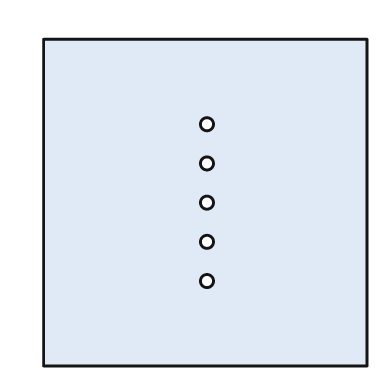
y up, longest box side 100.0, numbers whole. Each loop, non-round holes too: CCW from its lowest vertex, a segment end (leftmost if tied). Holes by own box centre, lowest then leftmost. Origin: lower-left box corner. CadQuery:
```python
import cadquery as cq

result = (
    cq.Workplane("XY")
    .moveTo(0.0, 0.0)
    .lineTo(99.0, 0.0)
    .lineTo(99.0, 100.0)
    .lineTo(0.0, 100.0)
    .close()
    .moveTo(50.0, 26.0)
    .circle(2.0)
    .moveTo(50.0, 38.0)
    .circle(2.0)
    .moveTo(50.0, 50.0)
    .circle(2.0)
    .moveTo(50.0, 62.0)
    .circle(2.0)
    .moveTo(50.0, 74.0)
    .circle(2.0)
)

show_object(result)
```